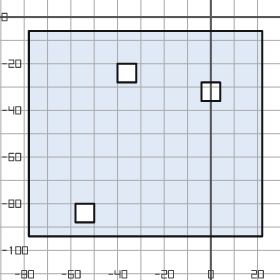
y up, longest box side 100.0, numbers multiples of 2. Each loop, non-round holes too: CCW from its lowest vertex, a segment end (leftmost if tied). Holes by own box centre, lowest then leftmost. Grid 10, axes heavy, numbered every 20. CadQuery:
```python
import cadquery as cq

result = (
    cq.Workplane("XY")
    .moveTo(-78.0, -94.0)
    .lineTo(22.0, -94.0)
    .lineTo(22.0, -6.0)
    .lineTo(-78.0, -6.0)
    .close()
    .moveTo(-58.0, -88.0)
    .lineTo(-50.0, -88.0)
    .lineTo(-50.0, -80.0)
    .lineTo(-58.0, -80.0)
    .close()
    .moveTo(-4.0, -36.0)
    .lineTo(4.0, -36.0)
    .lineTo(4.0, -28.0)
    .lineTo(-4.0, -28.0)
    .close()
    .moveTo(-40.0, -28.0)
    .lineTo(-32.0, -28.0)
    .lineTo(-32.0, -20.0)
    .lineTo(-40.0, -20.0)
    .close()
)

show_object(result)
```